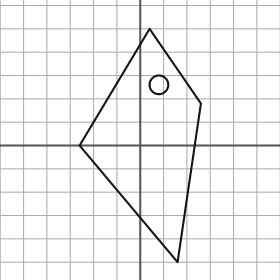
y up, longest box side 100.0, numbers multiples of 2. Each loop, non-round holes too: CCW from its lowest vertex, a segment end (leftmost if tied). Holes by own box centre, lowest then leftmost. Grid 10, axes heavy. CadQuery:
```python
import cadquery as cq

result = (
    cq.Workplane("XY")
    .moveTo(16.0, -50.0)
    .lineTo(26.0, 18.0)
    .lineTo(4.0, 50.0)
    .lineTo(-26.0, 0.0)
    .close()
    .moveTo(8.0, 26.0)
    .circle(4.0)
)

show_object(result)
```